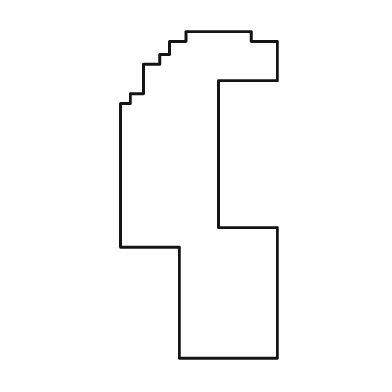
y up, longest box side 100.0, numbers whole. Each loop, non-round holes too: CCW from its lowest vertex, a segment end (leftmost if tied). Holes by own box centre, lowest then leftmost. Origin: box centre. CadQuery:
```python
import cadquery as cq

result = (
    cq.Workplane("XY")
    .moveTo(-6.0, -50.0)
    .lineTo(24.0, -50.0)
    .lineTo(24.0, -10.0)
    .lineTo(6.0, -10.0)
    .lineTo(6.0, 35.0)
    .lineTo(24.0, 35.0)
    .lineTo(24.0, 47.0)
    .lineTo(16.0, 47.0)
    .lineTo(16.0, 50.0)
    .lineTo(-4.0, 50.0)
    .lineTo(-4.0, 47.0)
    .lineTo(-9.0, 47.0)
    .lineTo(-9.0, 43.0)
    .lineTo(-12.0, 43.0)
    .lineTo(-12.0, 40.0)
    .lineTo(-17.0, 40.0)
    .lineTo(-17.0, 31.0)
    .lineTo(-21.0, 31.0)
    .lineTo(-21.0, 28.0)
    .lineTo(-24.0, 28.0)
    .lineTo(-24.0, -16.0)
    .lineTo(-6.0, -16.0)
    .close()
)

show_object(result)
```